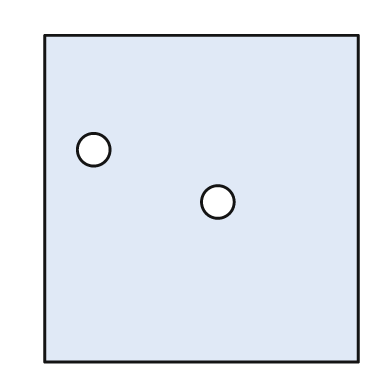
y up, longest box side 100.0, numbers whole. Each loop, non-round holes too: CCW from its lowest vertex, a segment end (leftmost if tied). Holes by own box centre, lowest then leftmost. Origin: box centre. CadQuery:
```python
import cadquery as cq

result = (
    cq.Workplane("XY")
    .moveTo(-48.0, -50.0)
    .lineTo(48.0, -50.0)
    .lineTo(48.0, 50.0)
    .lineTo(-48.0, 50.0)
    .close()
    .moveTo(5.0, -1.0)
    .circle(5.0)
    .moveTo(-33.0, 15.0)
    .circle(5.0)
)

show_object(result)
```